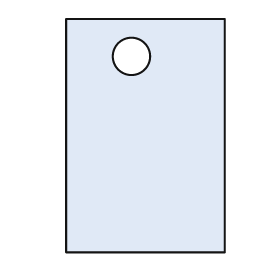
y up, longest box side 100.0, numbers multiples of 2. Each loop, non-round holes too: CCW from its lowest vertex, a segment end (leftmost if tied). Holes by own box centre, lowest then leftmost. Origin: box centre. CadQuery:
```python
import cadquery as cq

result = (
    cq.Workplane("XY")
    .moveTo(-34.0, -50.0)
    .lineTo(34.0, -50.0)
    .lineTo(34.0, 50.0)
    .lineTo(-34.0, 50.0)
    .close()
    .moveTo(-6.0, 34.0)
    .circle(8.0)
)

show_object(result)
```